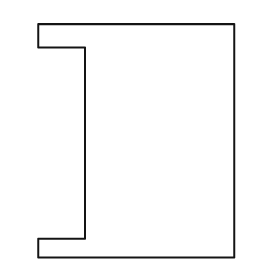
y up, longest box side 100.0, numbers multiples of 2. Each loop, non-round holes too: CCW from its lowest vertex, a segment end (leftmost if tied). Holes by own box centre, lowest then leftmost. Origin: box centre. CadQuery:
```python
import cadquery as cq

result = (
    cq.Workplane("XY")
    .moveTo(-42.0, -50.0)
    .lineTo(42.0, -50.0)
    .lineTo(42.0, 50.0)
    .lineTo(-42.0, 50.0)
    .lineTo(-42.0, 40.0)
    .lineTo(-22.0, 40.0)
    .lineTo(-22.0, -42.0)
    .lineTo(-42.0, -42.0)
    .close()
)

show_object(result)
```